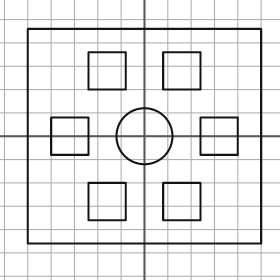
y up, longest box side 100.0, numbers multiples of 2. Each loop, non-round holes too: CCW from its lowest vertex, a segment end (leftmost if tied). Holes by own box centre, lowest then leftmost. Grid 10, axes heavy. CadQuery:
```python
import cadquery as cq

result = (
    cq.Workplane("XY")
    .moveTo(-50.0, -46.0)
    .lineTo(50.0, -46.0)
    .lineTo(50.0, 46.0)
    .lineTo(-50.0, 46.0)
    .close()
    .moveTo(-24.0, -36.0)
    .lineTo(-8.0, -36.0)
    .lineTo(-8.0, -20.0)
    .lineTo(-24.0, -20.0)
    .close()
    .moveTo(8.0, -36.0)
    .lineTo(24.0, -36.0)
    .lineTo(24.0, -20.0)
    .lineTo(8.0, -20.0)
    .close()
    .moveTo(-40.0, -8.0)
    .lineTo(-24.0, -8.0)
    .lineTo(-24.0, 8.0)
    .lineTo(-40.0, 8.0)
    .close()
    .moveTo(0.0, 0.0)
    .circle(12.0)
    .moveTo(24.0, -8.0)
    .lineTo(40.0, -8.0)
    .lineTo(40.0, 8.0)
    .lineTo(24.0, 8.0)
    .close()
    .moveTo(-24.0, 20.0)
    .lineTo(-8.0, 20.0)
    .lineTo(-8.0, 36.0)
    .lineTo(-24.0, 36.0)
    .close()
    .moveTo(8.0, 20.0)
    .lineTo(24.0, 20.0)
    .lineTo(24.0, 36.0)
    .lineTo(8.0, 36.0)
    .close()
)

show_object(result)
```